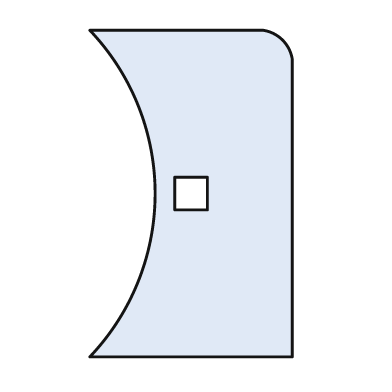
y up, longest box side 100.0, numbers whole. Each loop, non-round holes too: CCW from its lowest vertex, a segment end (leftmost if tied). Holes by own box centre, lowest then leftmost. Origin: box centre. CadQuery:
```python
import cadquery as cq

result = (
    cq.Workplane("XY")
    .moveTo(-31.0, -50.0)
    .lineTo(31.0, -50.0)
    .lineTo(31.0, 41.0)
    .threePointArc((28.0, 47.0), (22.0, 50.0))
    .lineTo(-31.0, 50.0)
    .threePointArc((-11.0, 0.0), (-31.0, -50.0))
    .close()
    .moveTo(-5.0, -5.0)
    .lineTo(5.0, -5.0)
    .lineTo(5.0, 5.0)
    .lineTo(-5.0, 5.0)
    .close()
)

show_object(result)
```